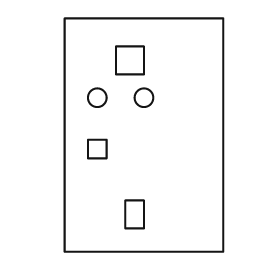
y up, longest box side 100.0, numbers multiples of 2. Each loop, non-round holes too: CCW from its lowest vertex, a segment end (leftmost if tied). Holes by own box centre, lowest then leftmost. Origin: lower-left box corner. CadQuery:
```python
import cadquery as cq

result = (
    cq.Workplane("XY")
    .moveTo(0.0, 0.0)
    .lineTo(68.0, 0.0)
    .lineTo(68.0, 100.0)
    .lineTo(0.0, 100.0)
    .close()
    .moveTo(26.0, 10.0)
    .lineTo(34.0, 10.0)
    .lineTo(34.0, 22.0)
    .lineTo(26.0, 22.0)
    .close()
    .moveTo(10.0, 40.0)
    .lineTo(18.0, 40.0)
    .lineTo(18.0, 48.0)
    .lineTo(10.0, 48.0)
    .close()
    .moveTo(14.0, 66.0)
    .circle(4.0)
    .moveTo(34.0, 66.0)
    .circle(4.0)
    .moveTo(22.0, 76.0)
    .lineTo(34.0, 76.0)
    .lineTo(34.0, 88.0)
    .lineTo(22.0, 88.0)
    .close()
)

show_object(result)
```